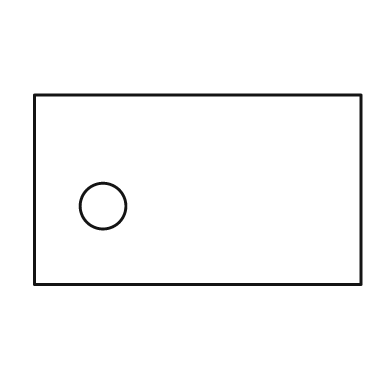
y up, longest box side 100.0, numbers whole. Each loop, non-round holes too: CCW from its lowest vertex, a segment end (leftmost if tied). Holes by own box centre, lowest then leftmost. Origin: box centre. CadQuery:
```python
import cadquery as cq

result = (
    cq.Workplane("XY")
    .moveTo(-50.0, -29.0)
    .lineTo(50.0, -29.0)
    .lineTo(50.0, 29.0)
    .lineTo(-50.0, 29.0)
    .close()
    .moveTo(-29.0, -5.0)
    .circle(7.0)
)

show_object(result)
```